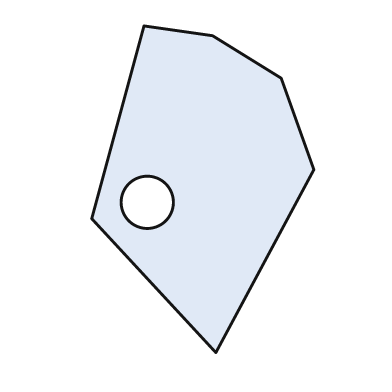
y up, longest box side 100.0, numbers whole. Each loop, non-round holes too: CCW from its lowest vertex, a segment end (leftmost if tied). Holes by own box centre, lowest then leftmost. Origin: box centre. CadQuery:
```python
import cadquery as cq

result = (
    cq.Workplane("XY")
    .moveTo(4.0, -50.0)
    .lineTo(34.0, 6.0)
    .lineTo(24.0, 34.0)
    .lineTo(3.0, 47.0)
    .lineTo(-18.0, 50.0)
    .lineTo(-34.0, -9.0)
    .close()
    .moveTo(-17.0, -4.0)
    .circle(8.0)
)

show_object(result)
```